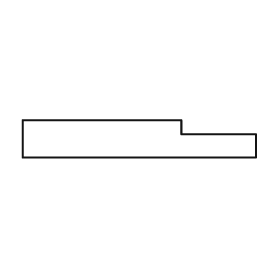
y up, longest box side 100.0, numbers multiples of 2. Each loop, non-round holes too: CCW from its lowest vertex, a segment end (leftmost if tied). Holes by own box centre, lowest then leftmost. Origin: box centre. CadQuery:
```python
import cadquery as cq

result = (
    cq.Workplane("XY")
    .moveTo(-50.0, -8.0)
    .lineTo(50.0, -8.0)
    .lineTo(50.0, 2.0)
    .lineTo(18.0, 2.0)
    .lineTo(18.0, 8.0)
    .lineTo(-50.0, 8.0)
    .close()
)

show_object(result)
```